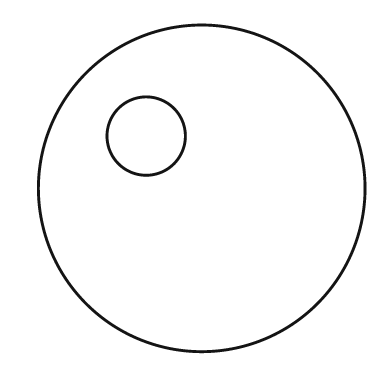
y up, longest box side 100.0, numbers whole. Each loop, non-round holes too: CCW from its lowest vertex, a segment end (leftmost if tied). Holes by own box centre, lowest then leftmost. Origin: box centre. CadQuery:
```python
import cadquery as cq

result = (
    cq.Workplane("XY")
    .moveTo(0.0, 0.0)
    .circle(50.0)
    .moveTo(-17.0, 16.0)
    .circle(12.0)
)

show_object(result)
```